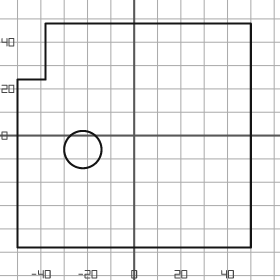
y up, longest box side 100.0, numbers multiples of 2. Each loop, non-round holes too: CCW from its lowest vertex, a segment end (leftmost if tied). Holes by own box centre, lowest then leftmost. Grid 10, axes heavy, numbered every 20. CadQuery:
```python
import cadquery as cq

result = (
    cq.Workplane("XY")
    .moveTo(-50.0, -48.0)
    .lineTo(50.0, -48.0)
    .lineTo(50.0, 48.0)
    .lineTo(-38.0, 48.0)
    .lineTo(-38.0, 24.0)
    .lineTo(-50.0, 24.0)
    .close()
    .moveTo(-22.0, -6.0)
    .circle(8.0)
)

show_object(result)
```